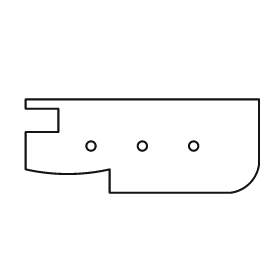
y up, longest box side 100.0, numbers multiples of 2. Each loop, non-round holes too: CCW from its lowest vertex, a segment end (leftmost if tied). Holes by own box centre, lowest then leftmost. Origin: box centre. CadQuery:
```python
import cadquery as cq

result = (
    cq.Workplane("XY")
    .moveTo(-14.0, -20.0)
    .lineTo(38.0, -20.0)
    .threePointArc((46.0, -16.0), (50.0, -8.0))
    .lineTo(50.0, 20.0)
    .lineTo(-50.0, 20.0)
    .lineTo(-50.0, 16.0)
    .lineTo(-36.0, 16.0)
    .lineTo(-36.0, 6.0)
    .lineTo(-50.0, 6.0)
    .lineTo(-50.0, -10.0)
    .threePointArc((-32.0, -12.0), (-14.0, -10.0))
    .close()
    .moveTo(-22.0, 0.0)
    .circle(2.0)
    .moveTo(0.0, 0.0)
    .circle(2.0)
    .moveTo(22.0, 0.0)
    .circle(2.0)
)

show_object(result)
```